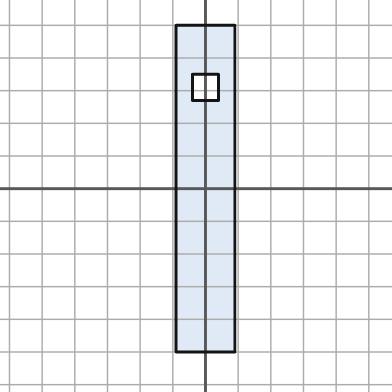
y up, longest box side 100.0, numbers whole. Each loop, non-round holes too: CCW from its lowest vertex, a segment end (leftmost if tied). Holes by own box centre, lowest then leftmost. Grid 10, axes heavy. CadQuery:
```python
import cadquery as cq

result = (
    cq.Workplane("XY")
    .moveTo(-9.0, -50.0)
    .lineTo(9.0, -50.0)
    .lineTo(9.0, 50.0)
    .lineTo(-9.0, 50.0)
    .close()
    .moveTo(-4.0, 27.0)
    .lineTo(4.0, 27.0)
    .lineTo(4.0, 35.0)
    .lineTo(-4.0, 35.0)
    .close()
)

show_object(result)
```